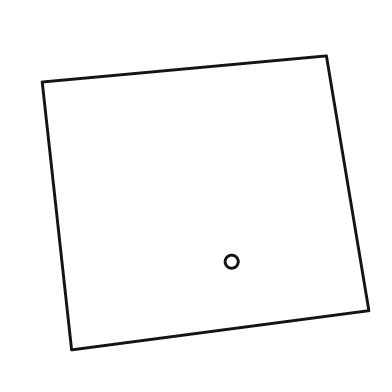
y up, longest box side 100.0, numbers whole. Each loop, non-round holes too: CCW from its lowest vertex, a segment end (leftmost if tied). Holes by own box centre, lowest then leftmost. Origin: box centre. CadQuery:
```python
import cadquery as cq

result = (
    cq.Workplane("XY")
    .moveTo(-41.0, -45.0)
    .lineTo(50.0, -33.0)
    .lineTo(37.0, 45.0)
    .lineTo(-50.0, 37.0)
    .close()
    .moveTo(8.0, -18.0)
    .circle(2.0)
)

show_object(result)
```